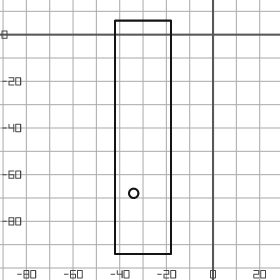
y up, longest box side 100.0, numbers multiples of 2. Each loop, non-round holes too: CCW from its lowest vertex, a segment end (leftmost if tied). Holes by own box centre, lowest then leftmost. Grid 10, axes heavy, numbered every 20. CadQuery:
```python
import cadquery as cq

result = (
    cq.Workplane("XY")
    .moveTo(-42.0, -94.0)
    .lineTo(-18.0, -94.0)
    .lineTo(-18.0, 6.0)
    .lineTo(-42.0, 6.0)
    .close()
    .moveTo(-34.0, -68.0)
    .circle(2.0)
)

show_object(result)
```